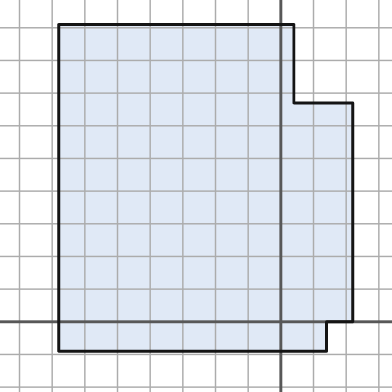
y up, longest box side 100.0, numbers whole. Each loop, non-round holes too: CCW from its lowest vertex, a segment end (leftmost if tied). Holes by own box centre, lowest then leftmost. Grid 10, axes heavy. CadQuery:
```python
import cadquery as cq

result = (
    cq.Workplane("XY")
    .moveTo(-68.0, -9.0)
    .lineTo(14.0, -9.0)
    .lineTo(14.0, 0.0)
    .lineTo(22.0, 0.0)
    .lineTo(22.0, 67.0)
    .lineTo(4.0, 67.0)
    .lineTo(4.0, 91.0)
    .lineTo(-68.0, 91.0)
    .close()
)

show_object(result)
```